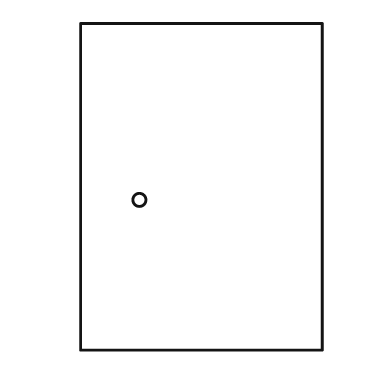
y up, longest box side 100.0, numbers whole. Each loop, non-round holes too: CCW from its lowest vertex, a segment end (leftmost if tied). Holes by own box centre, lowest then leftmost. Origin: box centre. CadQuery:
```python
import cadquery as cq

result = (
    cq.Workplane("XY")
    .moveTo(-37.0, -50.0)
    .lineTo(37.0, -50.0)
    .lineTo(37.0, 50.0)
    .lineTo(-37.0, 50.0)
    .close()
    .moveTo(-19.0, -4.0)
    .circle(2.0)
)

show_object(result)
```